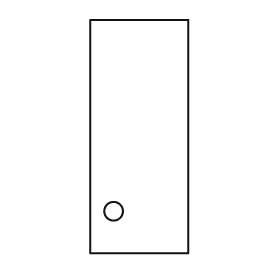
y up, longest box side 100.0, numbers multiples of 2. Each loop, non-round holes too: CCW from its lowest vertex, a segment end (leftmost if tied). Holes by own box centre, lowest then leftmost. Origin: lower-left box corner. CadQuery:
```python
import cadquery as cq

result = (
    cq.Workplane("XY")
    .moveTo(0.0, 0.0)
    .lineTo(42.0, 0.0)
    .lineTo(42.0, 100.0)
    .lineTo(0.0, 100.0)
    .close()
    .moveTo(10.0, 18.0)
    .circle(4.0)
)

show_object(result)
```